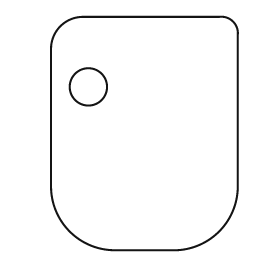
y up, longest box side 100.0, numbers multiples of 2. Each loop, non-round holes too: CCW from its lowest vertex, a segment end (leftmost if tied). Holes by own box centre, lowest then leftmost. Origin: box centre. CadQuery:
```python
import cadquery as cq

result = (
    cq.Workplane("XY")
    .moveTo(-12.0, -50.0)
    .lineTo(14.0, -50.0)
    .threePointArc((32.0, -42.0), (40.0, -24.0))
    .lineTo(40.0, 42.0)
    .threePointArc((38.0, 48.0), (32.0, 50.0))
    .lineTo(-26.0, 50.0)
    .threePointArc((-36.0, 46.0), (-40.0, 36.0))
    .lineTo(-40.0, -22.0)
    .threePointArc((-32.0, -42.0), (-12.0, -50.0))
    .close()
    .moveTo(-24.0, 20.0)
    .circle(8.0)
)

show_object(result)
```